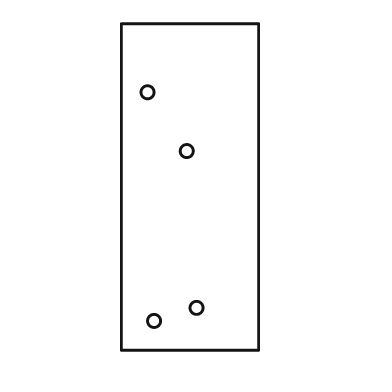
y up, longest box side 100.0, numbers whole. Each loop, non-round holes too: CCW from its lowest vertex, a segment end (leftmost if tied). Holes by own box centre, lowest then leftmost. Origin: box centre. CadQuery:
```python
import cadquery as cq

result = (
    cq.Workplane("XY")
    .moveTo(-21.0, -50.0)
    .lineTo(21.0, -50.0)
    .lineTo(21.0, 50.0)
    .lineTo(-21.0, 50.0)
    .close()
    .moveTo(-11.0, -41.0)
    .circle(2.0)
    .moveTo(2.0, -37.0)
    .circle(2.0)
    .moveTo(-1.0, 11.0)
    .circle(2.0)
    .moveTo(-13.0, 29.0)
    .circle(2.0)
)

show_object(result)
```